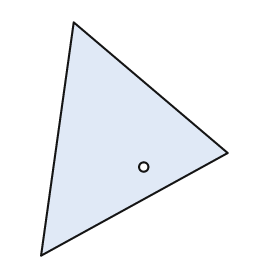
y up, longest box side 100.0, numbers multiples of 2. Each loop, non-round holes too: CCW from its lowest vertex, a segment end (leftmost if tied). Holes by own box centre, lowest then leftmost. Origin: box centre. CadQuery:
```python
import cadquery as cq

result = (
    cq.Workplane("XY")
    .moveTo(-40.0, -50.0)
    .lineTo(40.0, -6.0)
    .lineTo(-26.0, 50.0)
    .close()
    .moveTo(4.0, -12.0)
    .circle(2.0)
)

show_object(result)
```